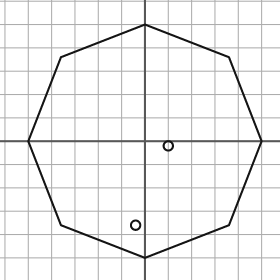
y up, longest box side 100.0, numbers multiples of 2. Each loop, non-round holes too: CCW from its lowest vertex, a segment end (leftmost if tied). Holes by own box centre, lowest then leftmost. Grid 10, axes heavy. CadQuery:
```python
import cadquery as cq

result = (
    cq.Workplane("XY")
    .moveTo(0.0, -50.0)
    .lineTo(36.0, -36.0)
    .lineTo(50.0, 0.0)
    .lineTo(36.0, 36.0)
    .lineTo(0.0, 50.0)
    .lineTo(-36.0, 36.0)
    .lineTo(-50.0, 0.0)
    .lineTo(-36.0, -36.0)
    .close()
    .moveTo(-4.0, -36.0)
    .circle(2.0)
    .moveTo(10.0, -2.0)
    .circle(2.0)
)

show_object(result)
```